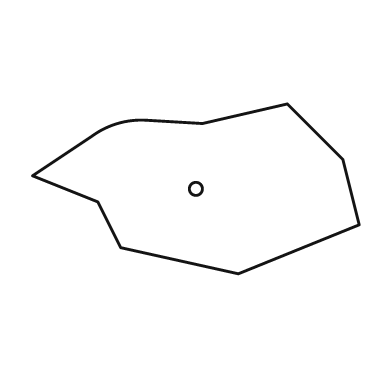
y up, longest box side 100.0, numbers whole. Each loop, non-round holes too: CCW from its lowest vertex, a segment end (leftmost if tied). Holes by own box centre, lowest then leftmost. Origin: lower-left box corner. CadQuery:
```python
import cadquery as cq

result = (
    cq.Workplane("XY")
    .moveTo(63.0, 0.0)
    .lineTo(100.0, 15.0)
    .lineTo(95.0, 35.0)
    .lineTo(78.0, 52.0)
    .lineTo(52.0, 46.0)
    .lineTo(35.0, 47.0)
    .threePointArc((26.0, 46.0), (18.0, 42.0))
    .lineTo(0.0, 30.0)
    .lineTo(20.0, 22.0)
    .lineTo(27.0, 8.0)
    .close()
    .moveTo(50.0, 26.0)
    .circle(2.0)
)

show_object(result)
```